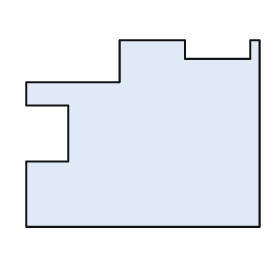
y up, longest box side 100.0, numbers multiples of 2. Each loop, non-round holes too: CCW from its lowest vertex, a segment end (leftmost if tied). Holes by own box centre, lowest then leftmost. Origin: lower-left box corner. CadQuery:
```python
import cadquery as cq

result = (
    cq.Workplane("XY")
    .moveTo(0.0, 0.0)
    .lineTo(100.0, 0.0)
    .lineTo(100.0, 80.0)
    .lineTo(96.0, 80.0)
    .lineTo(96.0, 72.0)
    .lineTo(68.0, 72.0)
    .lineTo(68.0, 80.0)
    .lineTo(40.0, 80.0)
    .lineTo(40.0, 62.0)
    .lineTo(0.0, 62.0)
    .lineTo(0.0, 52.0)
    .lineTo(18.0, 52.0)
    .lineTo(18.0, 28.0)
    .lineTo(0.0, 28.0)
    .close()
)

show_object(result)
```